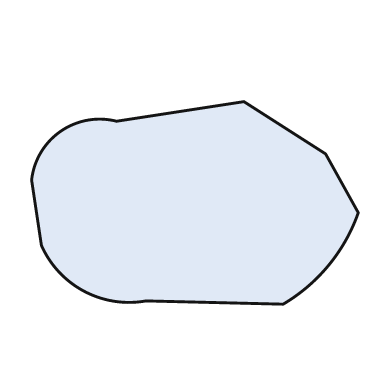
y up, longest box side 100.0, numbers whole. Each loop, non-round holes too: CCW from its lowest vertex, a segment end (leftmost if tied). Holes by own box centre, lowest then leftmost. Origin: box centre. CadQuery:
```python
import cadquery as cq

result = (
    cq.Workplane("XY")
    .moveTo(27.0, -31.0)
    .threePointArc((41.0, -19.0), (50.0, -3.0))
    .lineTo(40.0, 15.0)
    .lineTo(15.0, 31.0)
    .lineTo(-24.0, 25.0)
    .threePointArc((-41.0, 22.0), (-50.0, 7.0))
    .lineTo(-47.0, -13.0)
    .threePointArc((-34.0, -27.0), (-15.0, -30.0))
    .close()
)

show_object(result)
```